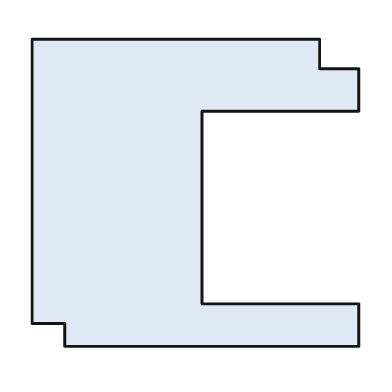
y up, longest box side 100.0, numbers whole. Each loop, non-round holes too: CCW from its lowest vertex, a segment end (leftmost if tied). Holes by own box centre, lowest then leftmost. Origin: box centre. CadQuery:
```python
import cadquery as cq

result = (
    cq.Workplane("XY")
    .moveTo(-40.0, -47.0)
    .lineTo(50.0, -47.0)
    .lineTo(50.0, -34.0)
    .lineTo(2.0, -34.0)
    .lineTo(2.0, 25.0)
    .lineTo(50.0, 25.0)
    .lineTo(50.0, 38.0)
    .lineTo(38.0, 38.0)
    .lineTo(38.0, 47.0)
    .lineTo(-50.0, 47.0)
    .lineTo(-50.0, -40.0)
    .lineTo(-40.0, -40.0)
    .close()
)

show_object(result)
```